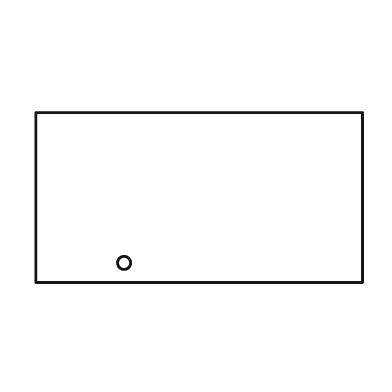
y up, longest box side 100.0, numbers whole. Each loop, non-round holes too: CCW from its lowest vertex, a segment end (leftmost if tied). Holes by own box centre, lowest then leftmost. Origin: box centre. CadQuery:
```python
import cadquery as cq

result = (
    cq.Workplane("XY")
    .moveTo(-50.0, -26.0)
    .lineTo(50.0, -26.0)
    .lineTo(50.0, 26.0)
    .lineTo(-50.0, 26.0)
    .close()
    .moveTo(-23.0, -20.0)
    .circle(2.0)
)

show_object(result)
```